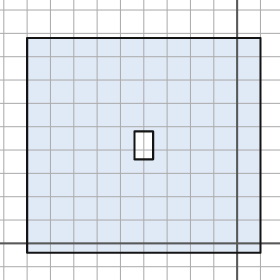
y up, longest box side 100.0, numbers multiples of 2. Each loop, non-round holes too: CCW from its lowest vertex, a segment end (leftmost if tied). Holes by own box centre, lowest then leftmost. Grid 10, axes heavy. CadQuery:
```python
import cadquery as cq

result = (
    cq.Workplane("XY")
    .moveTo(-90.0, -4.0)
    .lineTo(10.0, -4.0)
    .lineTo(10.0, 88.0)
    .lineTo(-90.0, 88.0)
    .close()
    .moveTo(-44.0, 36.0)
    .lineTo(-36.0, 36.0)
    .lineTo(-36.0, 48.0)
    .lineTo(-44.0, 48.0)
    .close()
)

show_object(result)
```